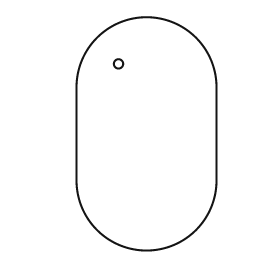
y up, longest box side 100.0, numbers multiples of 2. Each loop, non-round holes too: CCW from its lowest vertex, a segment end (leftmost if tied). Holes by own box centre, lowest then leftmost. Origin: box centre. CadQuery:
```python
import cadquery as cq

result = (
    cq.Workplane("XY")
    .moveTo(-30.0, -20.0)
    .threePointArc((0.0, -50.0), (30.0, -20.0))
    .lineTo(30.0, 20.0)
    .threePointArc((0.0, 50.0), (-30.0, 20.0))
    .close()
    .moveTo(-12.0, 30.0)
    .circle(2.0)
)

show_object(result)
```